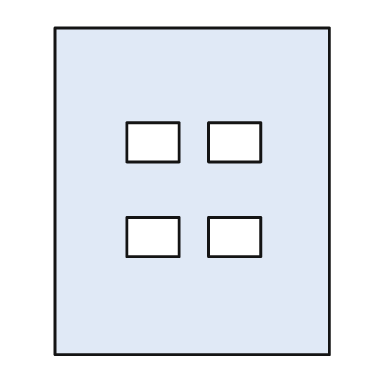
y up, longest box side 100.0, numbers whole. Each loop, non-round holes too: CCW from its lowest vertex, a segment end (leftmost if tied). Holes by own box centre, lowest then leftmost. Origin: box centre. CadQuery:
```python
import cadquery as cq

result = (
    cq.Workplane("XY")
    .moveTo(-42.0, -50.0)
    .lineTo(42.0, -50.0)
    .lineTo(42.0, 50.0)
    .lineTo(-42.0, 50.0)
    .close()
    .moveTo(-20.0, -20.0)
    .lineTo(-4.0, -20.0)
    .lineTo(-4.0, -8.0)
    .lineTo(-20.0, -8.0)
    .close()
    .moveTo(5.0, -20.0)
    .lineTo(21.0, -20.0)
    .lineTo(21.0, -8.0)
    .lineTo(5.0, -8.0)
    .close()
    .moveTo(-20.0, 9.0)
    .lineTo(-4.0, 9.0)
    .lineTo(-4.0, 21.0)
    .lineTo(-20.0, 21.0)
    .close()
    .moveTo(5.0, 9.0)
    .lineTo(21.0, 9.0)
    .lineTo(21.0, 21.0)
    .lineTo(5.0, 21.0)
    .close()
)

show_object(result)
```